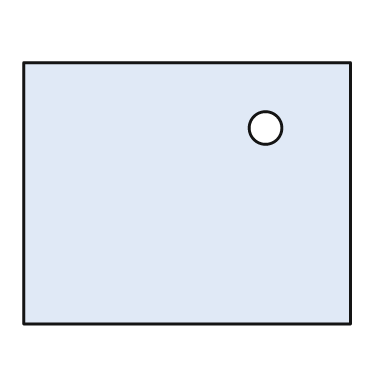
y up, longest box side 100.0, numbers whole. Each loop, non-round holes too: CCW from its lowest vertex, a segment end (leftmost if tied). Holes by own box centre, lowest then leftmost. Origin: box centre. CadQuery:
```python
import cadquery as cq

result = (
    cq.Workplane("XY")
    .moveTo(-50.0, -40.0)
    .lineTo(50.0, -40.0)
    .lineTo(50.0, 40.0)
    .lineTo(-50.0, 40.0)
    .close()
    .moveTo(24.0, 20.0)
    .circle(5.0)
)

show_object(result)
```